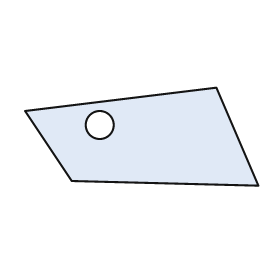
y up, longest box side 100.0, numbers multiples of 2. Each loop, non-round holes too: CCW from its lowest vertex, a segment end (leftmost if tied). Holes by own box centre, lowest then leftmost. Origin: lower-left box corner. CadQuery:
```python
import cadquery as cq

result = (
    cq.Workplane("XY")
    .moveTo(100.0, 0.0)
    .lineTo(82.0, 42.0)
    .lineTo(0.0, 32.0)
    .lineTo(20.0, 2.0)
    .close()
    .moveTo(32.0, 26.0)
    .circle(6.0)
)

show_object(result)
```